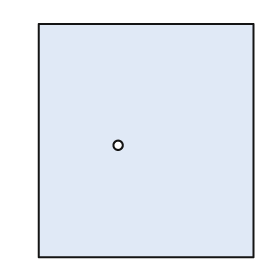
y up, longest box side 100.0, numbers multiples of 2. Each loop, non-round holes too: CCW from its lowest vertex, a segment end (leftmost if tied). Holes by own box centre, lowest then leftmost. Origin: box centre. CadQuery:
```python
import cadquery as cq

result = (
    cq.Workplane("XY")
    .moveTo(-46.0, -50.0)
    .lineTo(46.0, -50.0)
    .lineTo(46.0, 50.0)
    .lineTo(-46.0, 50.0)
    .close()
    .moveTo(-12.0, -2.0)
    .circle(2.0)
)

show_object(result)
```